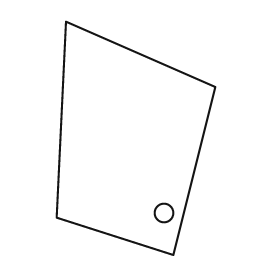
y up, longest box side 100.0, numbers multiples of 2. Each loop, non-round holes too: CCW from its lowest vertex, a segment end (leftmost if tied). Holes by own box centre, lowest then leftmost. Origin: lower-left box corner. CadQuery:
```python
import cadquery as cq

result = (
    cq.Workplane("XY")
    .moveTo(50.0, 0.0)
    .lineTo(68.0, 72.0)
    .lineTo(4.0, 100.0)
    .lineTo(0.0, 16.0)
    .close()
    .moveTo(46.0, 18.0)
    .circle(4.0)
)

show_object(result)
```